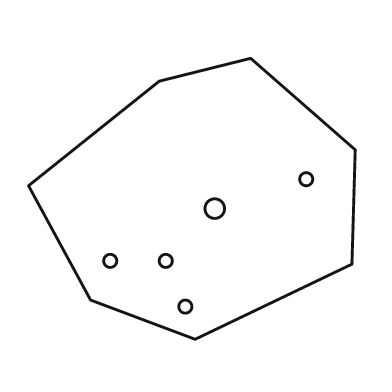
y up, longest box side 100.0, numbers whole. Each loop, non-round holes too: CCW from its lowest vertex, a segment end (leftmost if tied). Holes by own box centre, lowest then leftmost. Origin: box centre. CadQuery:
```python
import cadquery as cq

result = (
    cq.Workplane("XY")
    .moveTo(1.0, -43.0)
    .lineTo(49.0, -20.0)
    .lineTo(50.0, 15.0)
    .lineTo(18.0, 43.0)
    .lineTo(-10.0, 36.0)
    .lineTo(-50.0, 4.0)
    .lineTo(-31.0, -31.0)
    .close()
    .moveTo(-2.0, -33.0)
    .circle(2.0)
    .moveTo(-25.0, -19.0)
    .circle(2.0)
    .moveTo(-8.0, -19.0)
    .circle(2.0)
    .moveTo(7.0, -3.0)
    .circle(3.0)
    .moveTo(35.0, 6.0)
    .circle(2.0)
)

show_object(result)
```